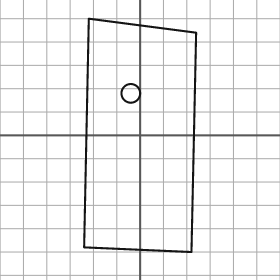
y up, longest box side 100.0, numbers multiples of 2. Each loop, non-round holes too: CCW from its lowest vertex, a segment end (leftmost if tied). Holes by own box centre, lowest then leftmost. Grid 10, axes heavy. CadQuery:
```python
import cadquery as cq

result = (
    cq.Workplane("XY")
    .moveTo(22.0, -50.0)
    .lineTo(24.0, 44.0)
    .lineTo(-22.0, 50.0)
    .lineTo(-24.0, -48.0)
    .close()
    .moveTo(-4.0, 18.0)
    .circle(4.0)
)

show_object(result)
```